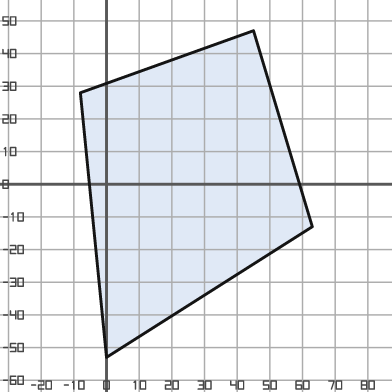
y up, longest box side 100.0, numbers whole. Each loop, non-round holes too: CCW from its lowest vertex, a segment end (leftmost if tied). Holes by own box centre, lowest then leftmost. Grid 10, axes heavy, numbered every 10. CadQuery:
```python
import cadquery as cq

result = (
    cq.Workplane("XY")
    .moveTo(0.0, -53.0)
    .lineTo(63.0, -13.0)
    .lineTo(45.0, 47.0)
    .lineTo(-8.0, 28.0)
    .close()
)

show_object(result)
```